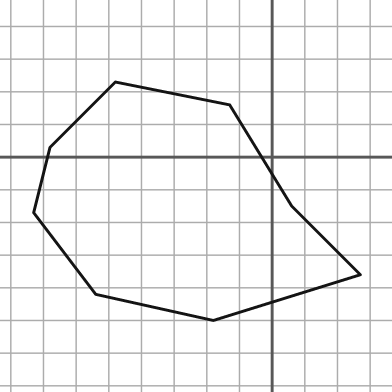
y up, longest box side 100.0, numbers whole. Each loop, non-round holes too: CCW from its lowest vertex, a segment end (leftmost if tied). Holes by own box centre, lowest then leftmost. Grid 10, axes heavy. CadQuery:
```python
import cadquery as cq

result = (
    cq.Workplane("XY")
    .moveTo(-18.0, -50.0)
    .lineTo(27.0, -36.0)
    .lineTo(6.0, -15.0)
    .lineTo(-13.0, 16.0)
    .lineTo(-48.0, 23.0)
    .lineTo(-68.0, 3.0)
    .lineTo(-73.0, -17.0)
    .lineTo(-54.0, -42.0)
    .close()
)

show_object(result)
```